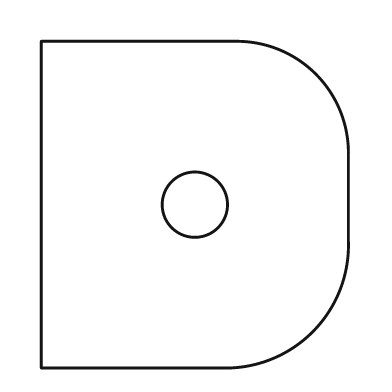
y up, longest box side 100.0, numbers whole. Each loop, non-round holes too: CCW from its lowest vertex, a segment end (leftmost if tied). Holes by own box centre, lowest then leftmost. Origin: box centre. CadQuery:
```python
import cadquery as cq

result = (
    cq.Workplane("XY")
    .moveTo(-47.0, -50.0)
    .lineTo(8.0, -50.0)
    .threePointArc((36.0, -39.0), (47.0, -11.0))
    .lineTo(47.0, 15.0)
    .threePointArc((37.0, 40.0), (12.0, 50.0))
    .lineTo(-47.0, 50.0)
    .close()
    .moveTo(0.0, 0.0)
    .circle(10.0)
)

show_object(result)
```